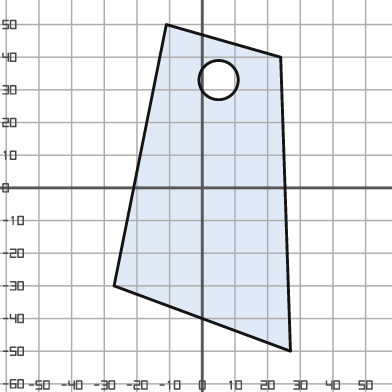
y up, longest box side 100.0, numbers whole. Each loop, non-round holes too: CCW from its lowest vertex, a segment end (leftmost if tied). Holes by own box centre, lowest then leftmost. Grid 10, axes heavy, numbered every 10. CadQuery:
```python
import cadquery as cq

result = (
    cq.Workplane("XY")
    .moveTo(27.0, -50.0)
    .lineTo(24.0, 40.0)
    .lineTo(-11.0, 50.0)
    .lineTo(-27.0, -30.0)
    .close()
    .moveTo(5.0, 33.0)
    .circle(6.0)
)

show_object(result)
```